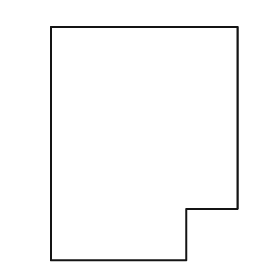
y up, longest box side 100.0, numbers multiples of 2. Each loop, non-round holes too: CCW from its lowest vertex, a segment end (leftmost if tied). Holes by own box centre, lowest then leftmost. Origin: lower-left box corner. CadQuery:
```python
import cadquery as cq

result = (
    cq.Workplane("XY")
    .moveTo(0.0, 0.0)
    .lineTo(58.0, 0.0)
    .lineTo(58.0, 22.0)
    .lineTo(80.0, 22.0)
    .lineTo(80.0, 100.0)
    .lineTo(0.0, 100.0)
    .close()
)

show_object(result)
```